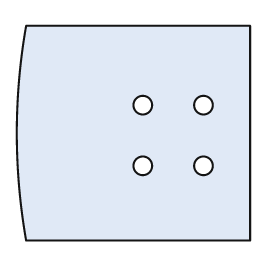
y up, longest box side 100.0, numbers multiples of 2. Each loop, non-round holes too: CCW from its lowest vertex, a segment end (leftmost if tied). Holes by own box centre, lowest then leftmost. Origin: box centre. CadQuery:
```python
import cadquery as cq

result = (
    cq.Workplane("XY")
    .moveTo(-46.0, -46.0)
    .lineTo(50.0, -46.0)
    .lineTo(50.0, 46.0)
    .lineTo(-46.0, 46.0)
    .threePointArc((-50.0, 0.0), (-46.0, -46.0))
    .close()
    .moveTo(4.0, -14.0)
    .circle(4.0)
    .moveTo(30.0, -14.0)
    .circle(4.0)
    .moveTo(4.0, 12.0)
    .circle(4.0)
    .moveTo(30.0, 12.0)
    .circle(4.0)
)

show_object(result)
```